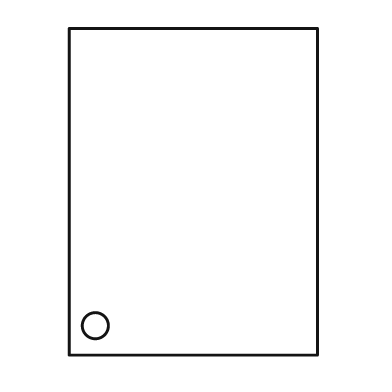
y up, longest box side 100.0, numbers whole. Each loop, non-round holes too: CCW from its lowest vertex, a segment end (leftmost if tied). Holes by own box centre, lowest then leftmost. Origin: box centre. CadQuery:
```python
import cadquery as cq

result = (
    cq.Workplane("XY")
    .moveTo(-38.0, -50.0)
    .lineTo(38.0, -50.0)
    .lineTo(38.0, 50.0)
    .lineTo(-38.0, 50.0)
    .close()
    .moveTo(-30.0, -41.0)
    .circle(4.0)
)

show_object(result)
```